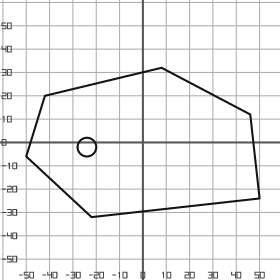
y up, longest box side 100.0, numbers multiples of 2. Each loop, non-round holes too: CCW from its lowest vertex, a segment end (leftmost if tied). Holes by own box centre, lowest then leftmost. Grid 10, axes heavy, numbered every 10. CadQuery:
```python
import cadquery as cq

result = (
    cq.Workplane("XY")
    .moveTo(-22.0, -32.0)
    .lineTo(50.0, -24.0)
    .lineTo(46.0, 12.0)
    .lineTo(8.0, 32.0)
    .lineTo(-42.0, 20.0)
    .lineTo(-50.0, -6.0)
    .close()
    .moveTo(-24.0, -2.0)
    .circle(4.0)
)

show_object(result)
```